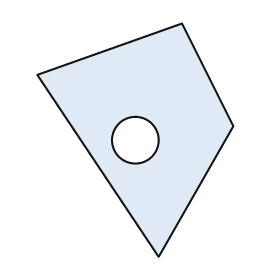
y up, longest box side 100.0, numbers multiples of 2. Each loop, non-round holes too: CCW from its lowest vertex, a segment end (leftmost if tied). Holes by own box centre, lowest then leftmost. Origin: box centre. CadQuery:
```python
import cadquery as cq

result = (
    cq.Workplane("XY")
    .moveTo(10.0, -50.0)
    .lineTo(42.0, 6.0)
    .lineTo(20.0, 50.0)
    .lineTo(-42.0, 28.0)
    .close()
    .moveTo(0.0, 0.0)
    .circle(10.0)
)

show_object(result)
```